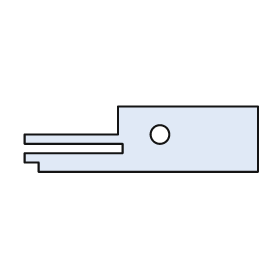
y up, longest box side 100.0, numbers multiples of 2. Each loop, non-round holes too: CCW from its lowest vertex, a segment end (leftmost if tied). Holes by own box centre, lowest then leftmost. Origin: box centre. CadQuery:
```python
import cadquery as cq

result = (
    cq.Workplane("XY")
    .moveTo(-44.0, -14.0)
    .lineTo(50.0, -14.0)
    .lineTo(50.0, 14.0)
    .lineTo(-10.0, 14.0)
    .lineTo(-10.0, 2.0)
    .lineTo(-50.0, 2.0)
    .lineTo(-50.0, -2.0)
    .lineTo(-8.0, -2.0)
    .lineTo(-8.0, -6.0)
    .lineTo(-50.0, -6.0)
    .lineTo(-50.0, -10.0)
    .lineTo(-44.0, -10.0)
    .close()
    .moveTo(8.0, 2.0)
    .circle(4.0)
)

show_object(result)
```